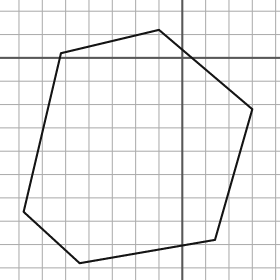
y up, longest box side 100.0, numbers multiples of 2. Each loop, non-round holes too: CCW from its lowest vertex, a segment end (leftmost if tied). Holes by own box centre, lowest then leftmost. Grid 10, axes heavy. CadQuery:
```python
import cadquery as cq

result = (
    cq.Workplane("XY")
    .moveTo(-44.0, -88.0)
    .lineTo(14.0, -78.0)
    .lineTo(30.0, -22.0)
    .lineTo(-10.0, 12.0)
    .lineTo(-52.0, 2.0)
    .lineTo(-68.0, -66.0)
    .close()
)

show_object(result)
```